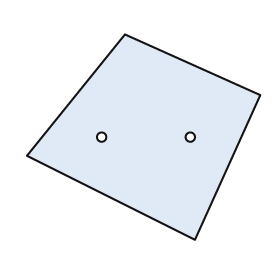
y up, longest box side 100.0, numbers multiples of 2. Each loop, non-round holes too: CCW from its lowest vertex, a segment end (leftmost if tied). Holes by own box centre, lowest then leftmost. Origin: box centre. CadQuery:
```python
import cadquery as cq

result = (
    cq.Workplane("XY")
    .moveTo(22.0, -44.0)
    .lineTo(50.0, 18.0)
    .lineTo(-8.0, 44.0)
    .lineTo(-50.0, -8.0)
    .close()
    .moveTo(-18.0, 0.0)
    .circle(2.0)
    .moveTo(20.0, 0.0)
    .circle(2.0)
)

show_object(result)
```